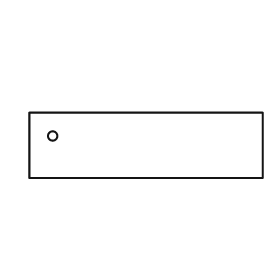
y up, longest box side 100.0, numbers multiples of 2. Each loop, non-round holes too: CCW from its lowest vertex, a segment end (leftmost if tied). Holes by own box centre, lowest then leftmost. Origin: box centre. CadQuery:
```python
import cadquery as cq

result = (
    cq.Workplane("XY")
    .moveTo(-50.0, -14.0)
    .lineTo(50.0, -14.0)
    .lineTo(50.0, 14.0)
    .lineTo(-50.0, 14.0)
    .close()
    .moveTo(-40.0, 4.0)
    .circle(2.0)
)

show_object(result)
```